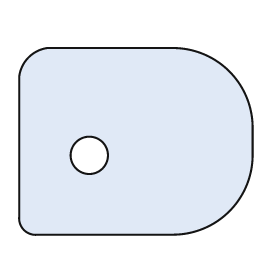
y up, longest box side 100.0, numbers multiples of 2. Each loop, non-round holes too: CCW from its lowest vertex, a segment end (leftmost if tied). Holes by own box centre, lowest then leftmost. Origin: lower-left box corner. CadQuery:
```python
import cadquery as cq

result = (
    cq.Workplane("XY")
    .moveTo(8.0, 0.0)
    .lineTo(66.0, 0.0)
    .threePointArc((90.0, 10.0), (100.0, 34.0))
    .lineTo(100.0, 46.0)
    .threePointArc((90.0, 70.0), (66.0, 80.0))
    .lineTo(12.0, 80.0)
    .threePointArc((4.0, 76.0), (0.0, 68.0))
    .lineTo(0.0, 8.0)
    .threePointArc((2.0, 2.0), (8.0, 0.0))
    .close()
    .moveTo(30.0, 34.0)
    .circle(8.0)
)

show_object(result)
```